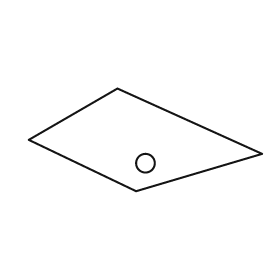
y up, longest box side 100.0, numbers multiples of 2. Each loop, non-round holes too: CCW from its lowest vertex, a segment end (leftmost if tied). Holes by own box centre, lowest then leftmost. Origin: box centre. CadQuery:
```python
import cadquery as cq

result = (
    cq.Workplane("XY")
    .moveTo(-4.0, -22.0)
    .lineTo(50.0, -6.0)
    .lineTo(-12.0, 22.0)
    .lineTo(-50.0, 0.0)
    .close()
    .moveTo(0.0, -10.0)
    .circle(4.0)
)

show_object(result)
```